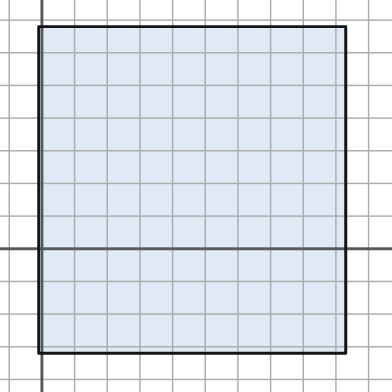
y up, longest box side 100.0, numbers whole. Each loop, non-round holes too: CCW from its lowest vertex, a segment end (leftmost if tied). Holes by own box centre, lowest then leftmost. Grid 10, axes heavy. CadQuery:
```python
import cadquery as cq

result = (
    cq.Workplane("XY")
    .moveTo(-1.0, -32.0)
    .lineTo(93.0, -32.0)
    .lineTo(93.0, 68.0)
    .lineTo(-1.0, 68.0)
    .close()
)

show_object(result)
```